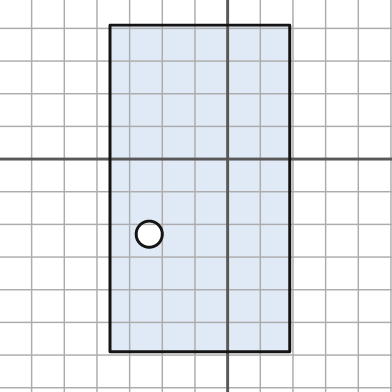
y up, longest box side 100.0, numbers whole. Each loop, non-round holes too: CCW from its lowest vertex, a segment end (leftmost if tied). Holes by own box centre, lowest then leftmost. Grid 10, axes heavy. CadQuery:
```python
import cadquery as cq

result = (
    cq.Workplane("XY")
    .moveTo(-36.0, -59.0)
    .lineTo(19.0, -59.0)
    .lineTo(19.0, 41.0)
    .lineTo(-36.0, 41.0)
    .close()
    .moveTo(-24.0, -23.0)
    .circle(4.0)
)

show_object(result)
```